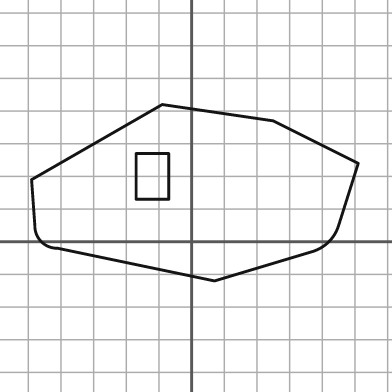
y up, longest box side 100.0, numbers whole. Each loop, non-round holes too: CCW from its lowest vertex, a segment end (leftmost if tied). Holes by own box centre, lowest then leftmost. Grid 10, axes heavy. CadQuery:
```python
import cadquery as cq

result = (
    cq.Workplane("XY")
    .moveTo(7.0, -12.0)
    .lineTo(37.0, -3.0)
    .threePointArc((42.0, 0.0), (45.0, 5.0))
    .lineTo(51.0, 24.0)
    .lineTo(25.0, 37.0)
    .lineTo(-9.0, 42.0)
    .lineTo(-49.0, 19.0)
    .lineTo(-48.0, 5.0)
    .threePointArc((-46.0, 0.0), (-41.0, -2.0))
    .close()
    .moveTo(-17.0, 13.0)
    .lineTo(-7.0, 13.0)
    .lineTo(-7.0, 27.0)
    .lineTo(-17.0, 27.0)
    .close()
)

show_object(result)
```